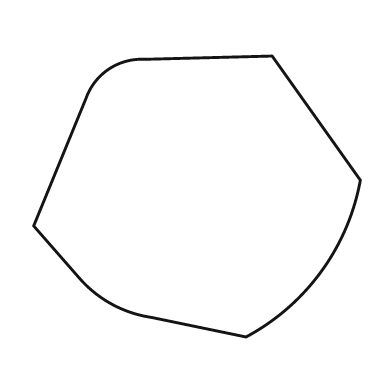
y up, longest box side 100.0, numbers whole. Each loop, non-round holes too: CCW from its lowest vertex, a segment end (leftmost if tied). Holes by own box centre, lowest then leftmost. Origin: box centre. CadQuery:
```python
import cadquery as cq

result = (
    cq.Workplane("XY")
    .moveTo(15.0, -43.0)
    .threePointArc((38.0, -23.0), (50.0, 5.0))
    .lineTo(23.0, 43.0)
    .lineTo(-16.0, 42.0)
    .threePointArc((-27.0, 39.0), (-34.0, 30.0))
    .lineTo(-50.0, -9.0)
    .lineTo(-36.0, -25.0)
    .threePointArc((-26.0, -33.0), (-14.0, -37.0))
    .close()
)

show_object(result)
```